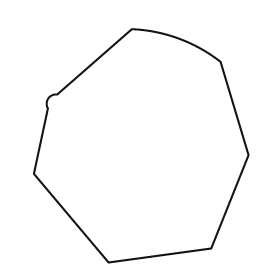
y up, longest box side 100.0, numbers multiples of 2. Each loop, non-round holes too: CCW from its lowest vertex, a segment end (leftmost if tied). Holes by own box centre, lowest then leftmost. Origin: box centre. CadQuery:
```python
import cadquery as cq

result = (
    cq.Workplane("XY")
    .moveTo(-14.0, -50.0)
    .lineTo(30.0, -44.0)
    .lineTo(46.0, -4.0)
    .lineTo(34.0, 36.0)
    .threePointArc((16.0, 46.0), (-4.0, 50.0))
    .lineTo(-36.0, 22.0)
    .threePointArc((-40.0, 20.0), (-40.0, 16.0))
    .lineTo(-46.0, -12.0)
    .close()
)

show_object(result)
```